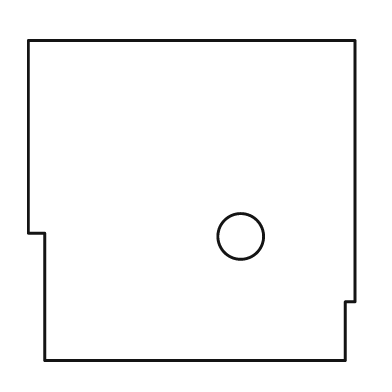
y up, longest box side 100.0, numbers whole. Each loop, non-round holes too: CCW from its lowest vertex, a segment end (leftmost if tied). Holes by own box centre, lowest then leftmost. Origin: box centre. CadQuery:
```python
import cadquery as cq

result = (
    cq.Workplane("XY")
    .moveTo(-45.0, -49.0)
    .lineTo(47.0, -49.0)
    .lineTo(47.0, -31.0)
    .lineTo(50.0, -31.0)
    .lineTo(50.0, 49.0)
    .lineTo(-50.0, 49.0)
    .lineTo(-50.0, -10.0)
    .lineTo(-45.0, -10.0)
    .close()
    .moveTo(15.0, -11.0)
    .circle(7.0)
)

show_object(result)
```